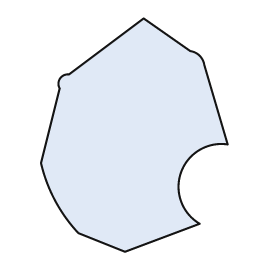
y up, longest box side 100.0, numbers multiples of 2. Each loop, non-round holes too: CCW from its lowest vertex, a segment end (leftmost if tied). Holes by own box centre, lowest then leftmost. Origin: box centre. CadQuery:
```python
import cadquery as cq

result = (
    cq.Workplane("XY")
    .moveTo(-4.0, -50.0)
    .lineTo(28.0, -38.0)
    .threePointArc((20.0, -16.0), (40.0, -4.0))
    .lineTo(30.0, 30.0)
    .threePointArc((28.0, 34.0), (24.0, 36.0))
    .lineTo(4.0, 50.0)
    .lineTo(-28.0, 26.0)
    .threePointArc((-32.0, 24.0), (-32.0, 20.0))
    .lineTo(-40.0, -12.0)
    .threePointArc((-34.0, -28.0), (-24.0, -42.0))
    .close()
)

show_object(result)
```